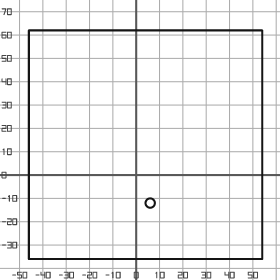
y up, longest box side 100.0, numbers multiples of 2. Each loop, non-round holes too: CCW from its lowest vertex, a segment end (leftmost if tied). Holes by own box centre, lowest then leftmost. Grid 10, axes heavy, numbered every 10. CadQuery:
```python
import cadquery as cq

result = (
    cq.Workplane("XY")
    .moveTo(-46.0, -36.0)
    .lineTo(54.0, -36.0)
    .lineTo(54.0, 62.0)
    .lineTo(-46.0, 62.0)
    .close()
    .moveTo(6.0, -12.0)
    .circle(2.0)
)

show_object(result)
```